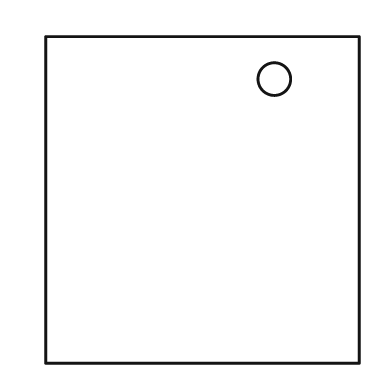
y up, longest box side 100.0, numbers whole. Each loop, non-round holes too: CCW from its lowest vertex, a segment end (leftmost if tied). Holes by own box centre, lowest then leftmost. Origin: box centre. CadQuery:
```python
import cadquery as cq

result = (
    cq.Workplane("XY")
    .moveTo(-48.0, -50.0)
    .lineTo(48.0, -50.0)
    .lineTo(48.0, 50.0)
    .lineTo(-48.0, 50.0)
    .close()
    .moveTo(22.0, 37.0)
    .circle(5.0)
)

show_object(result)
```